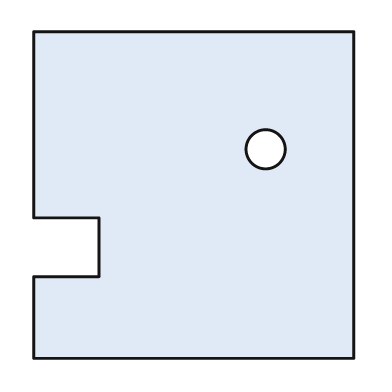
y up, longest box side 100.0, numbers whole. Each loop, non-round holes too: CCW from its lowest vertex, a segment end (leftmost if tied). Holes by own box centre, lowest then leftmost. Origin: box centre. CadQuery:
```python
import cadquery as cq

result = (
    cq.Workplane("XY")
    .moveTo(-49.0, -50.0)
    .lineTo(49.0, -50.0)
    .lineTo(49.0, 50.0)
    .lineTo(-49.0, 50.0)
    .lineTo(-49.0, -7.0)
    .lineTo(-29.0, -7.0)
    .lineTo(-29.0, -25.0)
    .lineTo(-49.0, -25.0)
    .close()
    .moveTo(22.0, 14.0)
    .circle(6.0)
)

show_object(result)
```